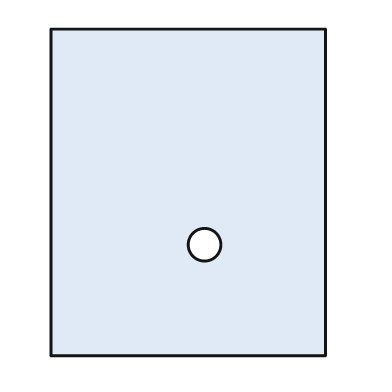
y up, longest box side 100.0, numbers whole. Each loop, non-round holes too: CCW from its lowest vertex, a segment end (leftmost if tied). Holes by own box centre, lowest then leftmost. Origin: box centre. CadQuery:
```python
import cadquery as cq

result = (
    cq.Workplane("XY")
    .moveTo(-42.0, -50.0)
    .lineTo(42.0, -50.0)
    .lineTo(42.0, 50.0)
    .lineTo(-42.0, 50.0)
    .close()
    .moveTo(5.0, -16.0)
    .circle(5.0)
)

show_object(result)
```